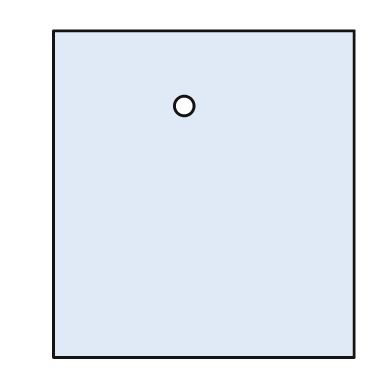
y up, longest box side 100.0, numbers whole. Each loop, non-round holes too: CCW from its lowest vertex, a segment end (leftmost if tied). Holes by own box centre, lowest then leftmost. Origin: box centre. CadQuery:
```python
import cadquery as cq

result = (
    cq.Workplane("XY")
    .moveTo(-46.0, -50.0)
    .lineTo(46.0, -50.0)
    .lineTo(46.0, 50.0)
    .lineTo(-46.0, 50.0)
    .close()
    .moveTo(-6.0, 27.0)
    .circle(3.0)
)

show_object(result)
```